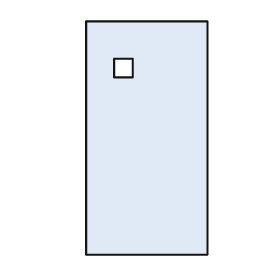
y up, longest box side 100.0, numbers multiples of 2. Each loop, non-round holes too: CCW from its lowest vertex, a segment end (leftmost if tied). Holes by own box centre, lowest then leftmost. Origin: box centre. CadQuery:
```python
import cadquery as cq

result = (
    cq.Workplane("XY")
    .moveTo(-26.0, -50.0)
    .lineTo(26.0, -50.0)
    .lineTo(26.0, 50.0)
    .lineTo(-26.0, 50.0)
    .close()
    .moveTo(-14.0, 26.0)
    .lineTo(-6.0, 26.0)
    .lineTo(-6.0, 34.0)
    .lineTo(-14.0, 34.0)
    .close()
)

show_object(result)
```